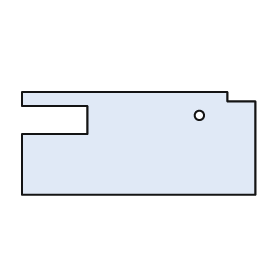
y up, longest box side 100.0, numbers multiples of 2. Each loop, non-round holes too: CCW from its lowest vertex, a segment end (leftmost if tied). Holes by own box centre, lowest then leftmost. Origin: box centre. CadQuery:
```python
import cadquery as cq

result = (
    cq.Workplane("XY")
    .moveTo(-50.0, -22.0)
    .lineTo(50.0, -22.0)
    .lineTo(50.0, 18.0)
    .lineTo(38.0, 18.0)
    .lineTo(38.0, 22.0)
    .lineTo(-50.0, 22.0)
    .lineTo(-50.0, 16.0)
    .lineTo(-22.0, 16.0)
    .lineTo(-22.0, 4.0)
    .lineTo(-50.0, 4.0)
    .close()
    .moveTo(26.0, 12.0)
    .circle(2.0)
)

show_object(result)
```